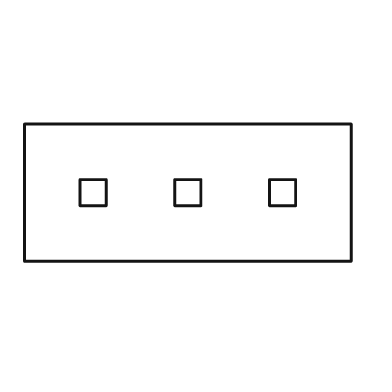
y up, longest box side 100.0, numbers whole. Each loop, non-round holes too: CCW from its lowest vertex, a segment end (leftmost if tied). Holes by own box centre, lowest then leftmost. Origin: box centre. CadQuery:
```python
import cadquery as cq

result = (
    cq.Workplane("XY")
    .moveTo(-50.0, -21.0)
    .lineTo(50.0, -21.0)
    .lineTo(50.0, 21.0)
    .lineTo(-50.0, 21.0)
    .close()
    .moveTo(-33.0, -4.0)
    .lineTo(-25.0, -4.0)
    .lineTo(-25.0, 4.0)
    .lineTo(-33.0, 4.0)
    .close()
    .moveTo(-4.0, -4.0)
    .lineTo(4.0, -4.0)
    .lineTo(4.0, 4.0)
    .lineTo(-4.0, 4.0)
    .close()
    .moveTo(25.0, -4.0)
    .lineTo(33.0, -4.0)
    .lineTo(33.0, 4.0)
    .lineTo(25.0, 4.0)
    .close()
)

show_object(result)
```